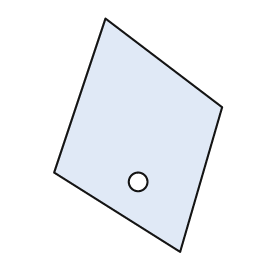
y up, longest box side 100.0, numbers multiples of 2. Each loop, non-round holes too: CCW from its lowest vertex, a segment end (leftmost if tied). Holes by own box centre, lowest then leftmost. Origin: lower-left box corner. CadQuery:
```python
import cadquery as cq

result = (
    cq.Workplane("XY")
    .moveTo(54.0, 0.0)
    .lineTo(72.0, 62.0)
    .lineTo(22.0, 100.0)
    .lineTo(0.0, 34.0)
    .close()
    .moveTo(36.0, 30.0)
    .circle(4.0)
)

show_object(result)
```